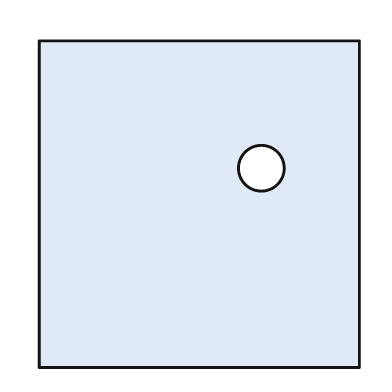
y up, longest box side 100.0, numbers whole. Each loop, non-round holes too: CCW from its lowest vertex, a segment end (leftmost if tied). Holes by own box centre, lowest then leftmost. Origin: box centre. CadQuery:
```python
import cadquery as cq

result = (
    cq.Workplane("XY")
    .moveTo(-49.0, -50.0)
    .lineTo(49.0, -50.0)
    .lineTo(49.0, 50.0)
    .lineTo(-49.0, 50.0)
    .close()
    .moveTo(19.0, 11.0)
    .circle(7.0)
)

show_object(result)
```